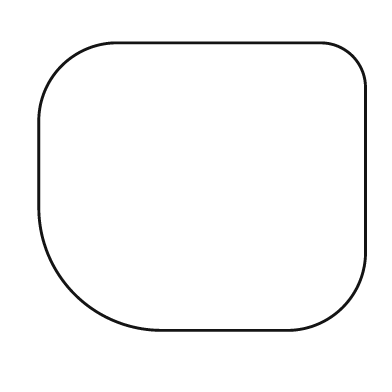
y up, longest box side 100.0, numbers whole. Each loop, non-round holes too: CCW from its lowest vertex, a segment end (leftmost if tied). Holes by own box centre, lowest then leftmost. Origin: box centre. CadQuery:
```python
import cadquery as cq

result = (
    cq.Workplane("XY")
    .moveTo(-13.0, -44.0)
    .lineTo(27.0, -44.0)
    .threePointArc((43.0, -37.0), (50.0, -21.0))
    .lineTo(50.0, 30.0)
    .threePointArc((46.0, 40.0), (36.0, 44.0))
    .lineTo(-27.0, 44.0)
    .threePointArc((-43.0, 37.0), (-50.0, 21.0))
    .lineTo(-50.0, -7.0)
    .threePointArc((-39.0, -33.0), (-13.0, -44.0))
    .close()
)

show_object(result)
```